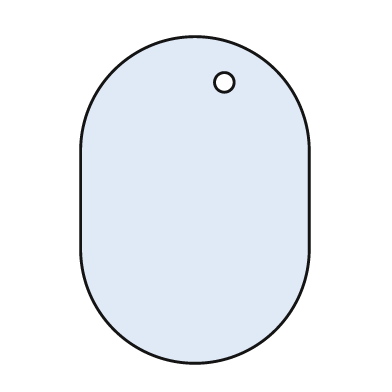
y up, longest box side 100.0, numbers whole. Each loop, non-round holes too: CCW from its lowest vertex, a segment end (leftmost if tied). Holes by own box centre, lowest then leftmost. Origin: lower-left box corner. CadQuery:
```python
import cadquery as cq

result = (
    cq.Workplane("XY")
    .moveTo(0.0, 35.0)
    .threePointArc((35.0, 0.0), (70.0, 35.0))
    .lineTo(70.0, 65.0)
    .threePointArc((35.0, 100.0), (0.0, 65.0))
    .close()
    .moveTo(44.0, 86.0)
    .circle(3.0)
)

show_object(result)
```